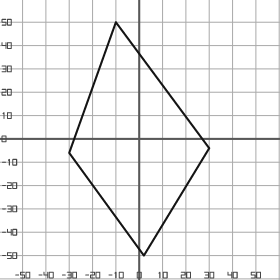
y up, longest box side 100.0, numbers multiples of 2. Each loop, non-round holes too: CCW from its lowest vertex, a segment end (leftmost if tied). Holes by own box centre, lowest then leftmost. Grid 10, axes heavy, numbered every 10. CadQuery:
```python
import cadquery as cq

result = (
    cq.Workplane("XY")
    .moveTo(2.0, -50.0)
    .lineTo(30.0, -4.0)
    .lineTo(-10.0, 50.0)
    .lineTo(-30.0, -6.0)
    .close()
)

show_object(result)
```